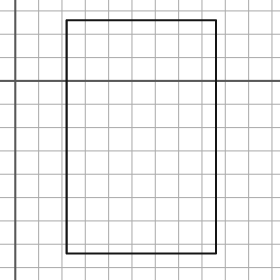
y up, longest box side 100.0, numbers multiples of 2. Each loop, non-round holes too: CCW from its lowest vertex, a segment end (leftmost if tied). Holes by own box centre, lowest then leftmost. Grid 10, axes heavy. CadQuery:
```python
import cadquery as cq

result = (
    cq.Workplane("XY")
    .moveTo(22.0, -74.0)
    .lineTo(86.0, -74.0)
    .lineTo(86.0, 26.0)
    .lineTo(22.0, 26.0)
    .close()
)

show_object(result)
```